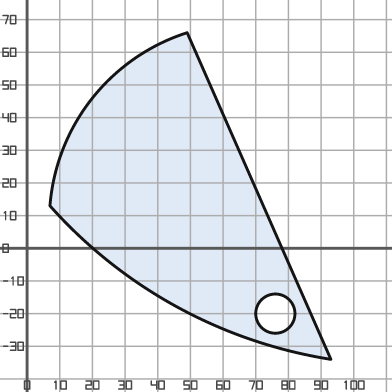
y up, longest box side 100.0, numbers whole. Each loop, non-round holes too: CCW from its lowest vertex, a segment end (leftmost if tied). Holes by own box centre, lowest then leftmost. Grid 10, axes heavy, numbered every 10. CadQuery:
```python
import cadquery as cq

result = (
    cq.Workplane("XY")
    .moveTo(93.0, -34.0)
    .lineTo(49.0, 66.0)
    .threePointArc((20.0, 46.0), (7.0, 13.0))
    .threePointArc((46.0, -18.0), (93.0, -34.0))
    .close()
    .moveTo(76.0, -20.0)
    .circle(6.0)
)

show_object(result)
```